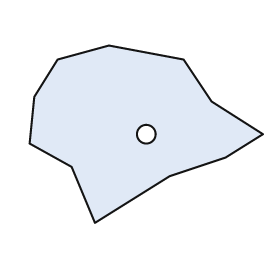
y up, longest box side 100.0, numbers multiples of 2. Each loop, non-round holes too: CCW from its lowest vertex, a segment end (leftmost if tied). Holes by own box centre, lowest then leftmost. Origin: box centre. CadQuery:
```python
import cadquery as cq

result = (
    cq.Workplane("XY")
    .moveTo(-22.0, -38.0)
    .lineTo(10.0, -18.0)
    .lineTo(34.0, -10.0)
    .lineTo(50.0, 0.0)
    .lineTo(28.0, 14.0)
    .lineTo(16.0, 32.0)
    .lineTo(-16.0, 38.0)
    .lineTo(-38.0, 32.0)
    .lineTo(-48.0, 16.0)
    .lineTo(-50.0, -4.0)
    .lineTo(-32.0, -14.0)
    .close()
    .moveTo(0.0, 0.0)
    .circle(4.0)
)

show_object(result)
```